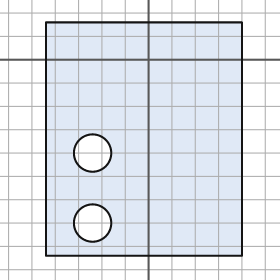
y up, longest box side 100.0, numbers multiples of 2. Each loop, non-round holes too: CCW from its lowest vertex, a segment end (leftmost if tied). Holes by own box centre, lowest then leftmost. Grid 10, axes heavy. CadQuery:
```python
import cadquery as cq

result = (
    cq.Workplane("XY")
    .moveTo(-44.0, -84.0)
    .lineTo(40.0, -84.0)
    .lineTo(40.0, 16.0)
    .lineTo(-44.0, 16.0)
    .close()
    .moveTo(-24.0, -70.0)
    .circle(8.0)
    .moveTo(-24.0, -40.0)
    .circle(8.0)
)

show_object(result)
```